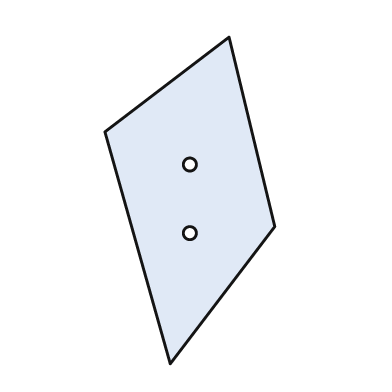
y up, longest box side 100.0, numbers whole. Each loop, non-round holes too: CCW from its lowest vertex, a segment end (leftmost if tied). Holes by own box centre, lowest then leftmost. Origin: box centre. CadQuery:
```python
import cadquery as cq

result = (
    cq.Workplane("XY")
    .moveTo(-6.0, -50.0)
    .lineTo(26.0, -8.0)
    .lineTo(12.0, 50.0)
    .lineTo(-26.0, 21.0)
    .close()
    .moveTo(0.0, -10.0)
    .circle(2.0)
    .moveTo(0.0, 11.0)
    .circle(2.0)
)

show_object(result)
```